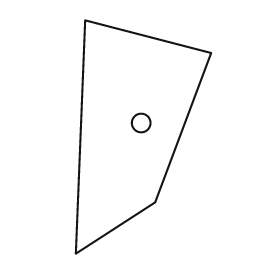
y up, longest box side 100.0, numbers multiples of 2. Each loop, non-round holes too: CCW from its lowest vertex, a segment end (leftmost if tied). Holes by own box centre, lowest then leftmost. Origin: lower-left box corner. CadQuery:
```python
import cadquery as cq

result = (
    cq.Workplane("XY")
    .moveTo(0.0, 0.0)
    .lineTo(34.0, 22.0)
    .lineTo(58.0, 86.0)
    .lineTo(4.0, 100.0)
    .close()
    .moveTo(28.0, 56.0)
    .circle(4.0)
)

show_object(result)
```